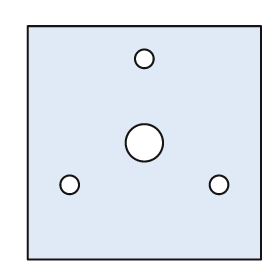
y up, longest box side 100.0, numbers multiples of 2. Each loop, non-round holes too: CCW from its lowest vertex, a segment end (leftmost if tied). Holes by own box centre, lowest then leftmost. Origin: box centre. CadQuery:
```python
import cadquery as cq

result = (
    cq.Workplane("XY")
    .moveTo(-50.0, -50.0)
    .lineTo(50.0, -50.0)
    .lineTo(50.0, 50.0)
    .lineTo(-50.0, 50.0)
    .close()
    .moveTo(-32.0, -18.0)
    .circle(4.0)
    .moveTo(32.0, -18.0)
    .circle(4.0)
    .moveTo(0.0, 0.0)
    .circle(8.0)
    .moveTo(0.0, 36.0)
    .circle(4.0)
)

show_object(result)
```